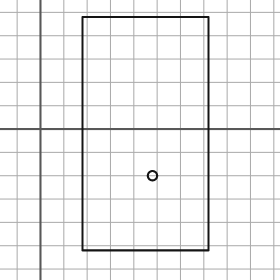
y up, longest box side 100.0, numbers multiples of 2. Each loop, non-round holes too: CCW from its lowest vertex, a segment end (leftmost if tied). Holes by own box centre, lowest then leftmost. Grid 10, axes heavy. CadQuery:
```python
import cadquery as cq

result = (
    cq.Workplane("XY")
    .moveTo(18.0, -52.0)
    .lineTo(72.0, -52.0)
    .lineTo(72.0, 48.0)
    .lineTo(18.0, 48.0)
    .close()
    .moveTo(48.0, -20.0)
    .circle(2.0)
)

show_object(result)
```